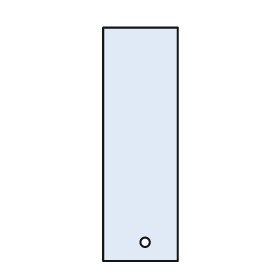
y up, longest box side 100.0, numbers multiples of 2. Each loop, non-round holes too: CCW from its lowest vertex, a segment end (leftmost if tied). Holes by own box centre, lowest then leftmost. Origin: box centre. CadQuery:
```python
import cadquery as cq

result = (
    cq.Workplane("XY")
    .moveTo(-16.0, -50.0)
    .lineTo(16.0, -50.0)
    .lineTo(16.0, 50.0)
    .lineTo(-16.0, 50.0)
    .close()
    .moveTo(2.0, -42.0)
    .circle(2.0)
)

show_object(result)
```